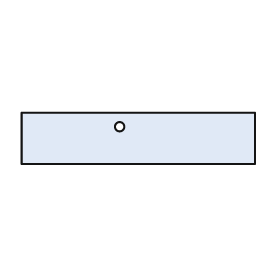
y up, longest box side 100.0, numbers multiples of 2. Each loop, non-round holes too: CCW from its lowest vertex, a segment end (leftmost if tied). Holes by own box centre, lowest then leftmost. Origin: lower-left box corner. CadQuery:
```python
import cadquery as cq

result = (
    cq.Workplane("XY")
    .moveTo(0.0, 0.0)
    .lineTo(100.0, 0.0)
    .lineTo(100.0, 22.0)
    .lineTo(0.0, 22.0)
    .close()
    .moveTo(42.0, 16.0)
    .circle(2.0)
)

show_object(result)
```